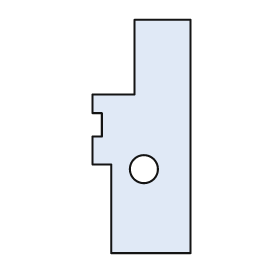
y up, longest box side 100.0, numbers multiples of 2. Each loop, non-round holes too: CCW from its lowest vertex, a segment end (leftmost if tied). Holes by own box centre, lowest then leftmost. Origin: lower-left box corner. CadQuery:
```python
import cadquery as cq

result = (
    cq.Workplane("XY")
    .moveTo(8.0, 0.0)
    .lineTo(42.0, 0.0)
    .lineTo(42.0, 100.0)
    .lineTo(18.0, 100.0)
    .lineTo(18.0, 68.0)
    .lineTo(0.0, 68.0)
    .lineTo(0.0, 60.0)
    .lineTo(4.0, 60.0)
    .lineTo(4.0, 50.0)
    .lineTo(0.0, 50.0)
    .lineTo(0.0, 38.0)
    .lineTo(8.0, 38.0)
    .close()
    .moveTo(22.0, 36.0)
    .circle(6.0)
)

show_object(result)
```